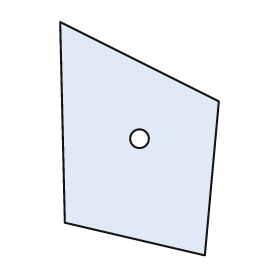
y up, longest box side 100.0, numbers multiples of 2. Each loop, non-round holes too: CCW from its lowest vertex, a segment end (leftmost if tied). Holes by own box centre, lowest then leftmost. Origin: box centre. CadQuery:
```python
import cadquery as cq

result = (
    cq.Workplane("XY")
    .moveTo(28.0, -50.0)
    .lineTo(34.0, 16.0)
    .lineTo(-34.0, 50.0)
    .lineTo(-32.0, -36.0)
    .close()
    .moveTo(0.0, 0.0)
    .circle(4.0)
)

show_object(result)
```